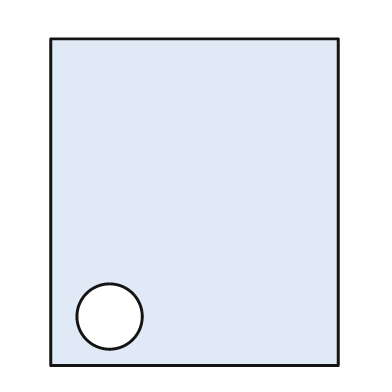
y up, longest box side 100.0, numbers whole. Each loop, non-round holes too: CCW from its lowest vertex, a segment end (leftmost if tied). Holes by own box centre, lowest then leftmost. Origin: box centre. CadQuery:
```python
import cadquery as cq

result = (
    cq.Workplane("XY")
    .moveTo(-44.0, -50.0)
    .lineTo(44.0, -50.0)
    .lineTo(44.0, 50.0)
    .lineTo(-44.0, 50.0)
    .close()
    .moveTo(-26.0, -35.0)
    .circle(10.0)
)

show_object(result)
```